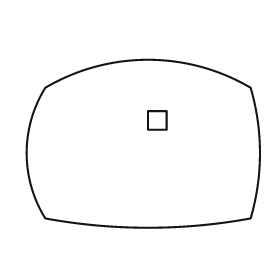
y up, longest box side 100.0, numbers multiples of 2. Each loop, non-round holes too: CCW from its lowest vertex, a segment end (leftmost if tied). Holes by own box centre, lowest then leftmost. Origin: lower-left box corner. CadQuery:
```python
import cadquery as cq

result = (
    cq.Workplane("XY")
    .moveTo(8.0, 4.0)
    .threePointArc((52.0, 0.0), (96.0, 4.0))
    .threePointArc((100.0, 32.0), (96.0, 60.0))
    .threePointArc((52.0, 72.0), (8.0, 60.0))
    .threePointArc((0.0, 32.0), (8.0, 4.0))
    .close()
    .moveTo(52.0, 42.0)
    .lineTo(60.0, 42.0)
    .lineTo(60.0, 50.0)
    .lineTo(52.0, 50.0)
    .close()
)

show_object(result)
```